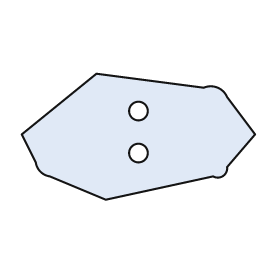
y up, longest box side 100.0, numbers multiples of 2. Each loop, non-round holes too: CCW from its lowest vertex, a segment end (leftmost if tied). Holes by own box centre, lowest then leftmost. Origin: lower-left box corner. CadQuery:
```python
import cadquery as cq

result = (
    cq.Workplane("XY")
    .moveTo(36.0, 0.0)
    .lineTo(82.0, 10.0)
    .threePointArc((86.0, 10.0), (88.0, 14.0))
    .lineTo(100.0, 28.0)
    .lineTo(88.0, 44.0)
    .threePointArc((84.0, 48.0), (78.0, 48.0))
    .lineTo(32.0, 54.0)
    .lineTo(0.0, 28.0)
    .lineTo(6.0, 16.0)
    .threePointArc((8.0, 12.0), (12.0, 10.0))
    .close()
    .moveTo(50.0, 20.0)
    .circle(4.0)
    .moveTo(50.0, 38.0)
    .circle(4.0)
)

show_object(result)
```